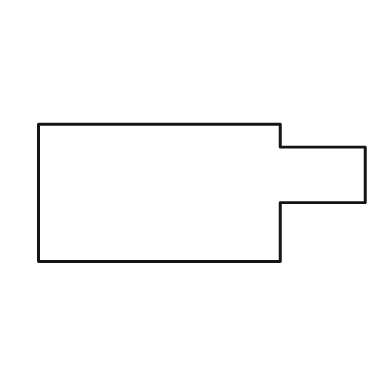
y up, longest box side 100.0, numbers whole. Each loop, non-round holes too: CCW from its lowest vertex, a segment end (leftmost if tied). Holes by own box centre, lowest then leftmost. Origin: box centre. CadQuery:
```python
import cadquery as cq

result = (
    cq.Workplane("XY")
    .moveTo(-50.0, -21.0)
    .lineTo(24.0, -21.0)
    .lineTo(24.0, -3.0)
    .lineTo(50.0, -3.0)
    .lineTo(50.0, 14.0)
    .lineTo(24.0, 14.0)
    .lineTo(24.0, 21.0)
    .lineTo(-50.0, 21.0)
    .close()
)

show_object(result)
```